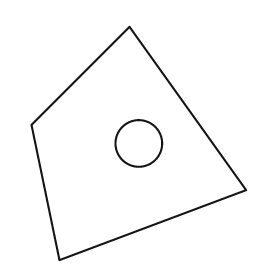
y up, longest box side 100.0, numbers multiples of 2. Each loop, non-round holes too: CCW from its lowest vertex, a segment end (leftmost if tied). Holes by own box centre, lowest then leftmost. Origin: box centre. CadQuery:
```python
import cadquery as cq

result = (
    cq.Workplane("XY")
    .moveTo(-34.0, -50.0)
    .lineTo(46.0, -20.0)
    .lineTo(-4.0, 50.0)
    .lineTo(-46.0, 8.0)
    .close()
    .moveTo(0.0, 0.0)
    .circle(10.0)
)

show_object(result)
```